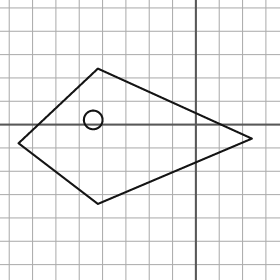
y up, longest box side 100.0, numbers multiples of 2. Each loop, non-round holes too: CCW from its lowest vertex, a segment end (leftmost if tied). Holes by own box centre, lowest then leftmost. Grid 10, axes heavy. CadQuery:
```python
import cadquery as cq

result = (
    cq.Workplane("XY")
    .moveTo(-42.0, -34.0)
    .lineTo(24.0, -6.0)
    .lineTo(-42.0, 24.0)
    .lineTo(-76.0, -8.0)
    .close()
    .moveTo(-44.0, 2.0)
    .circle(4.0)
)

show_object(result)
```